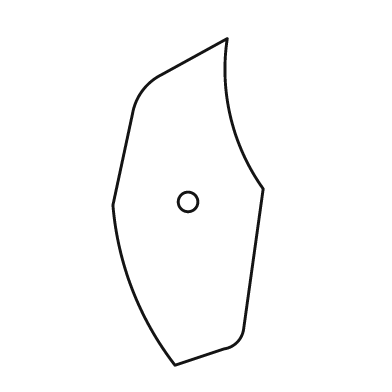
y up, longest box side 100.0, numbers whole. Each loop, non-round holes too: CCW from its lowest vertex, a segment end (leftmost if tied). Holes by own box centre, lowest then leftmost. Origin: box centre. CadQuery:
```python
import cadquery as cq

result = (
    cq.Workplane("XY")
    .moveTo(-4.0, -50.0)
    .lineTo(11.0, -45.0)
    .threePointArc((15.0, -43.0), (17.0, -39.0))
    .lineTo(23.0, 4.0)
    .threePointArc((13.0, 26.0), (12.0, 50.0))
    .lineTo(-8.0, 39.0)
    .threePointArc((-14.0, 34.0), (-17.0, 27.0))
    .lineTo(-23.0, -1.0)
    .threePointArc((-17.0, -27.0), (-4.0, -50.0))
    .close()
    .moveTo(0.0, 0.0)
    .circle(3.0)
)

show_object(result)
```